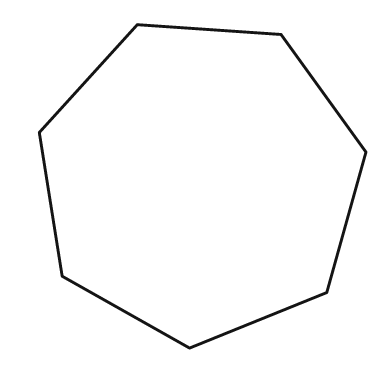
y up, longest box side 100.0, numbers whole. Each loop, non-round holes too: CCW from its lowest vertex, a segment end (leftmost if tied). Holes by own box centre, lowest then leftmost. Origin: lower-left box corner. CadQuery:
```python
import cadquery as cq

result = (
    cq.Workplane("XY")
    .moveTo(46.0, 0.0)
    .lineTo(88.0, 17.0)
    .lineTo(100.0, 60.0)
    .lineTo(74.0, 96.0)
    .lineTo(30.0, 99.0)
    .lineTo(0.0, 66.0)
    .lineTo(7.0, 22.0)
    .close()
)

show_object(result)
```